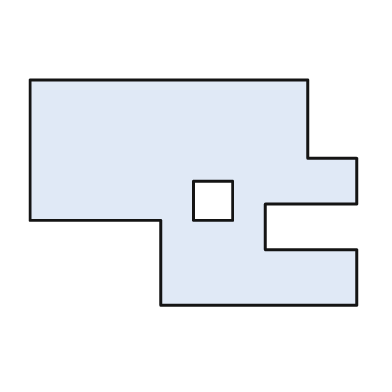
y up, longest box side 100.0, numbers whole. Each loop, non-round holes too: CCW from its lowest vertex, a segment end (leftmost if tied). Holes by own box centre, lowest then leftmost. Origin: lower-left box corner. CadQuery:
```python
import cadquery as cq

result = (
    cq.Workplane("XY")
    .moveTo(40.0, 0.0)
    .lineTo(100.0, 0.0)
    .lineTo(100.0, 17.0)
    .lineTo(72.0, 17.0)
    .lineTo(72.0, 31.0)
    .lineTo(100.0, 31.0)
    .lineTo(100.0, 45.0)
    .lineTo(85.0, 45.0)
    .lineTo(85.0, 69.0)
    .lineTo(0.0, 69.0)
    .lineTo(0.0, 26.0)
    .lineTo(40.0, 26.0)
    .close()
    .moveTo(50.0, 26.0)
    .lineTo(62.0, 26.0)
    .lineTo(62.0, 38.0)
    .lineTo(50.0, 38.0)
    .close()
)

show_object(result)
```